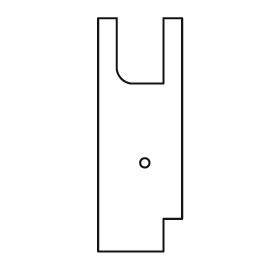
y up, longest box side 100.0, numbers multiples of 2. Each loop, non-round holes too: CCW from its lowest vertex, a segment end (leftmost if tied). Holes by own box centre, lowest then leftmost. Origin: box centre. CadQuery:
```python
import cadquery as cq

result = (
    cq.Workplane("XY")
    .moveTo(-18.0, -50.0)
    .lineTo(10.0, -50.0)
    .lineTo(10.0, -36.0)
    .lineTo(18.0, -36.0)
    .lineTo(18.0, 50.0)
    .lineTo(10.0, 50.0)
    .lineTo(10.0, 22.0)
    .lineTo(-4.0, 22.0)
    .threePointArc((-8.0, 24.0), (-10.0, 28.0))
    .lineTo(-10.0, 50.0)
    .lineTo(-18.0, 50.0)
    .close()
    .moveTo(2.0, -12.0)
    .circle(2.0)
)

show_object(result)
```